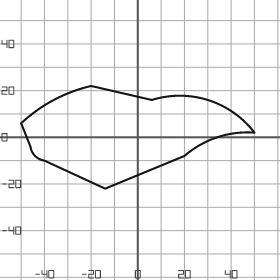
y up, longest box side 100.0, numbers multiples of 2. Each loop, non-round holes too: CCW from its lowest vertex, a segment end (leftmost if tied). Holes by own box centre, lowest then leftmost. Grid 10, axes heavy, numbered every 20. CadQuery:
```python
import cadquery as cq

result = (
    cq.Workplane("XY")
    .moveTo(-14.0, -22.0)
    .lineTo(20.0, -8.0)
    .threePointArc((34.0, 0.0), (50.0, 2.0))
    .threePointArc((30.0, 16.0), (6.0, 16.0))
    .lineTo(-20.0, 22.0)
    .threePointArc((-36.0, 16.0), (-50.0, 6.0))
    .lineTo(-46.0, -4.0)
    .threePointArc((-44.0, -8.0), (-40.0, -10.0))
    .close()
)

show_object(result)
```